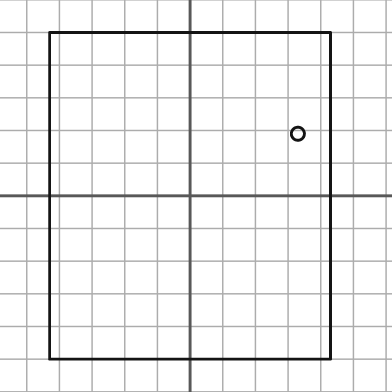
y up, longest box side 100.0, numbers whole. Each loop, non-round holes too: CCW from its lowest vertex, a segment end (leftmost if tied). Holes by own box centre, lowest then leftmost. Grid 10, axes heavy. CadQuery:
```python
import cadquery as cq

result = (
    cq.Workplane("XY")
    .moveTo(-43.0, -50.0)
    .lineTo(43.0, -50.0)
    .lineTo(43.0, 50.0)
    .lineTo(-43.0, 50.0)
    .close()
    .moveTo(33.0, 19.0)
    .circle(2.0)
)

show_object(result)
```